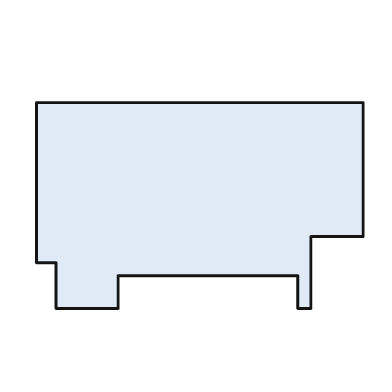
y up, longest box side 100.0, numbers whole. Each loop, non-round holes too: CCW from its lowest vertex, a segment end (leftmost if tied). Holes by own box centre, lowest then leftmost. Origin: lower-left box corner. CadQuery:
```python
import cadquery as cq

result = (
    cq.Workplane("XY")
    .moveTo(6.0, 0.0)
    .lineTo(25.0, 0.0)
    .lineTo(25.0, 10.0)
    .lineTo(80.0, 10.0)
    .lineTo(80.0, 0.0)
    .lineTo(84.0, 0.0)
    .lineTo(84.0, 22.0)
    .lineTo(100.0, 22.0)
    .lineTo(100.0, 63.0)
    .lineTo(0.0, 63.0)
    .lineTo(0.0, 14.0)
    .lineTo(6.0, 14.0)
    .close()
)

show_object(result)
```